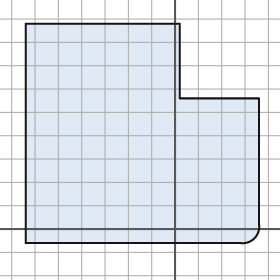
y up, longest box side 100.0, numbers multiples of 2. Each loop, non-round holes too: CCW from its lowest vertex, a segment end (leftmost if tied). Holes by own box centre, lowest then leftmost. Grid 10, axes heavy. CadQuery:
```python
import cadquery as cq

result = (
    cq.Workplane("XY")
    .moveTo(-64.0, -6.0)
    .lineTo(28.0, -6.0)
    .threePointArc((34.0, -4.0), (36.0, 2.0))
    .lineTo(36.0, 56.0)
    .lineTo(2.0, 56.0)
    .lineTo(2.0, 88.0)
    .lineTo(-64.0, 88.0)
    .close()
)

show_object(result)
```